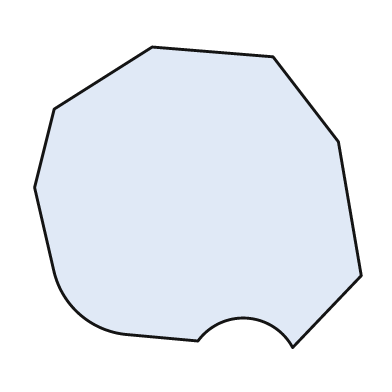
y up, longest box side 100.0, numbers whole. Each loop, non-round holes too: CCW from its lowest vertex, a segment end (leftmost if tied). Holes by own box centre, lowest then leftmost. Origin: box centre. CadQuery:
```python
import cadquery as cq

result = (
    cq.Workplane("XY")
    .moveTo(29.0, -46.0)
    .lineTo(50.0, -24.0)
    .lineTo(43.0, 17.0)
    .lineTo(23.0, 43.0)
    .lineTo(-14.0, 46.0)
    .lineTo(-44.0, 27.0)
    .lineTo(-50.0, 3.0)
    .lineTo(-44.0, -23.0)
    .threePointArc((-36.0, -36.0), (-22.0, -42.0))
    .lineTo(0.0, -44.0)
    .threePointArc((15.0, -37.0), (29.0, -46.0))
    .close()
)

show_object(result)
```